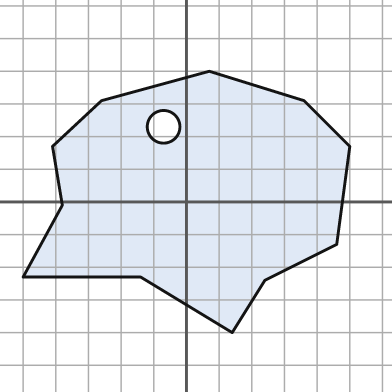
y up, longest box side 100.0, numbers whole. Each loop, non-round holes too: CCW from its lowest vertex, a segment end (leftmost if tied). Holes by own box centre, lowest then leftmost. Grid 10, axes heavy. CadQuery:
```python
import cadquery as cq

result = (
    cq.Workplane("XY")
    .moveTo(14.0, -40.0)
    .lineTo(24.0, -24.0)
    .lineTo(46.0, -13.0)
    .lineTo(50.0, 17.0)
    .lineTo(36.0, 31.0)
    .lineTo(7.0, 40.0)
    .lineTo(-26.0, 31.0)
    .lineTo(-41.0, 17.0)
    .lineTo(-38.0, -1.0)
    .lineTo(-50.0, -23.0)
    .lineTo(-14.0, -23.0)
    .close()
    .moveTo(-7.0, 23.0)
    .circle(5.0)
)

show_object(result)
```